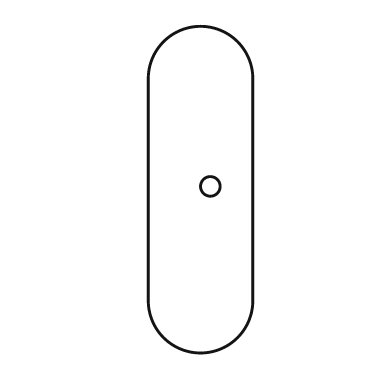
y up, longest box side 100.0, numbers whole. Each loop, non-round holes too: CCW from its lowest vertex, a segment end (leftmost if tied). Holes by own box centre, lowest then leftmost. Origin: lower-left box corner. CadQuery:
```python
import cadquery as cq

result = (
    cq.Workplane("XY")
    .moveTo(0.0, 16.0)
    .threePointArc((16.0, 0.0), (32.0, 16.0))
    .lineTo(32.0, 84.0)
    .threePointArc((16.0, 100.0), (0.0, 84.0))
    .close()
    .moveTo(19.0, 51.0)
    .circle(3.0)
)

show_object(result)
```